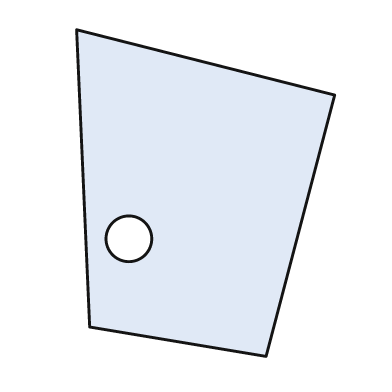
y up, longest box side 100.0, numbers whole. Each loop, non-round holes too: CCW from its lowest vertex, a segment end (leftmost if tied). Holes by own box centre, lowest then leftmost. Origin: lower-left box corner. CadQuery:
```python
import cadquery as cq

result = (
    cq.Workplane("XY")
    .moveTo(58.0, 0.0)
    .lineTo(79.0, 80.0)
    .lineTo(0.0, 100.0)
    .lineTo(4.0, 9.0)
    .close()
    .moveTo(16.0, 36.0)
    .circle(7.0)
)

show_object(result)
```